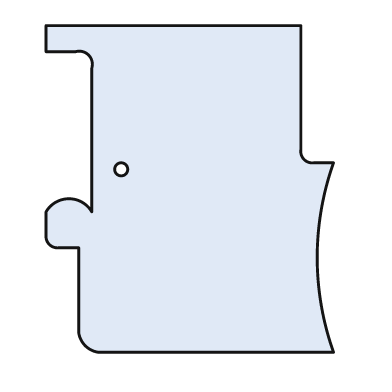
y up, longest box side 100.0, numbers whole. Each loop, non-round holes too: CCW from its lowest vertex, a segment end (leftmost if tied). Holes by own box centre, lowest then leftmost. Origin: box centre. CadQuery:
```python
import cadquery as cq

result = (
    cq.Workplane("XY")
    .moveTo(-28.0, -50.0)
    .lineTo(44.0, -50.0)
    .threePointArc((39.0, -21.0), (44.0, 8.0))
    .lineTo(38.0, 8.0)
    .threePointArc((35.0, 9.0), (34.0, 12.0))
    .lineTo(34.0, 50.0)
    .lineTo(-44.0, 50.0)
    .lineTo(-44.0, 42.0)
    .lineTo(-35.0, 42.0)
    .threePointArc((-31.0, 41.0), (-30.0, 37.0))
    .lineTo(-30.0, -7.0)
    .threePointArc((-37.0, -3.0), (-44.0, -7.0))
    .lineTo(-44.0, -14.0)
    .threePointArc((-43.0, -17.0), (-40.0, -18.0))
    .lineTo(-34.0, -18.0)
    .lineTo(-34.0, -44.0)
    .threePointArc((-32.0, -48.0), (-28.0, -50.0))
    .close()
    .moveTo(-21.0, 6.0)
    .circle(2.0)
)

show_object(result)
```